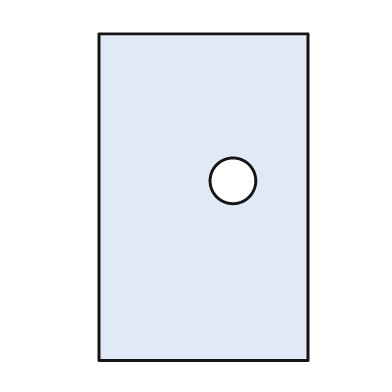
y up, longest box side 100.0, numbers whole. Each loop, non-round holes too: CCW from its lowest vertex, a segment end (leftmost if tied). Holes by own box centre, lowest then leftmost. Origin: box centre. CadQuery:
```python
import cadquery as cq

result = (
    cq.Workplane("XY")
    .moveTo(-32.0, -50.0)
    .lineTo(32.0, -50.0)
    .lineTo(32.0, 50.0)
    .lineTo(-32.0, 50.0)
    .close()
    .moveTo(9.0, 5.0)
    .circle(7.0)
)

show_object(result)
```